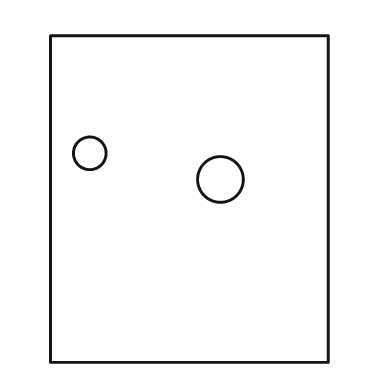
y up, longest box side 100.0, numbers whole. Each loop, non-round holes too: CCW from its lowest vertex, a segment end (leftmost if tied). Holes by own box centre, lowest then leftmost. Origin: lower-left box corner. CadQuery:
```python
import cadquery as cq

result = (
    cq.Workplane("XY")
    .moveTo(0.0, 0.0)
    .lineTo(85.0, 0.0)
    .lineTo(85.0, 100.0)
    .lineTo(0.0, 100.0)
    .close()
    .moveTo(52.0, 56.0)
    .circle(7.0)
    .moveTo(12.0, 64.0)
    .circle(5.0)
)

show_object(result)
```